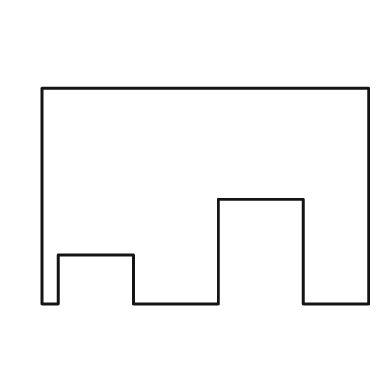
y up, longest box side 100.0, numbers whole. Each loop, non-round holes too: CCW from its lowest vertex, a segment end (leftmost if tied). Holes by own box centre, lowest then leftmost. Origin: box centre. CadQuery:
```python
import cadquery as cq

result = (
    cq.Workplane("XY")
    .moveTo(-50.0, -33.0)
    .lineTo(-45.0, -33.0)
    .lineTo(-45.0, -18.0)
    .lineTo(-22.0, -18.0)
    .lineTo(-22.0, -33.0)
    .lineTo(4.0, -33.0)
    .lineTo(4.0, -1.0)
    .lineTo(30.0, -1.0)
    .lineTo(30.0, -33.0)
    .lineTo(50.0, -33.0)
    .lineTo(50.0, 33.0)
    .lineTo(-50.0, 33.0)
    .close()
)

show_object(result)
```